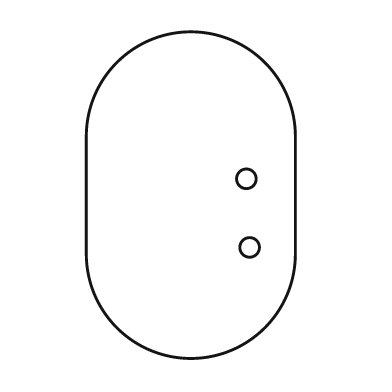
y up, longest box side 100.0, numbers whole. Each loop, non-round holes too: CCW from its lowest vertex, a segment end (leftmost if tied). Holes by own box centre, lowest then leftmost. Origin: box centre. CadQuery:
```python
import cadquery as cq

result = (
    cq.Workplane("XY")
    .moveTo(-32.0, -18.0)
    .threePointArc((0.0, -50.0), (32.0, -18.0))
    .lineTo(32.0, 18.0)
    .threePointArc((0.0, 50.0), (-32.0, 18.0))
    .close()
    .moveTo(18.0, -16.0)
    .circle(3.0)
    .moveTo(17.0, 5.0)
    .circle(3.0)
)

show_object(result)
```